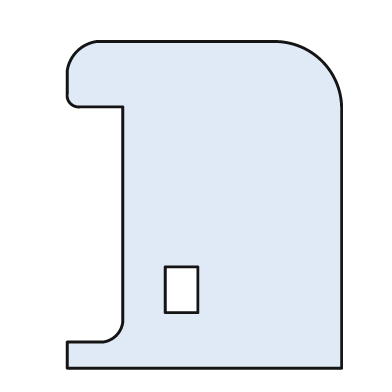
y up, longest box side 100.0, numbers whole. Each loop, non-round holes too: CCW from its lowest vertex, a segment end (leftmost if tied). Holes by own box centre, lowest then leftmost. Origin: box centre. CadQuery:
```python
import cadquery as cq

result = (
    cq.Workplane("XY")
    .moveTo(-42.0, -50.0)
    .lineTo(42.0, -50.0)
    .lineTo(42.0, 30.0)
    .threePointArc((36.0, 44.0), (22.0, 50.0))
    .lineTo(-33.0, 50.0)
    .threePointArc((-39.0, 47.0), (-42.0, 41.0))
    .lineTo(-42.0, 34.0)
    .threePointArc((-41.0, 31.0), (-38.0, 30.0))
    .lineTo(-25.0, 30.0)
    .lineTo(-25.0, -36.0)
    .threePointArc((-27.0, -40.0), (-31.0, -42.0))
    .lineTo(-42.0, -42.0)
    .close()
    .moveTo(-12.0, -33.0)
    .lineTo(-2.0, -33.0)
    .lineTo(-2.0, -19.0)
    .lineTo(-12.0, -19.0)
    .close()
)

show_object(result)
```